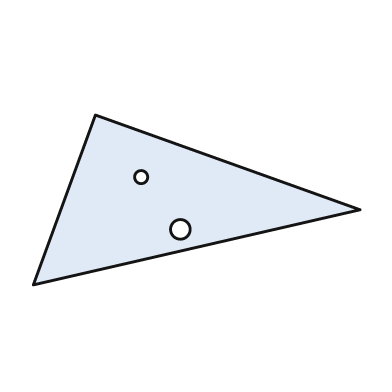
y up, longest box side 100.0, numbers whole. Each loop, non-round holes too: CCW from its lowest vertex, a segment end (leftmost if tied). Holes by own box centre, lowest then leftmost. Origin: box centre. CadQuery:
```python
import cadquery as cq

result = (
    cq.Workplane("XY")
    .moveTo(-50.0, -26.0)
    .lineTo(50.0, -3.0)
    .lineTo(-31.0, 26.0)
    .close()
    .moveTo(-5.0, -9.0)
    .circle(3.0)
    .moveTo(-17.0, 7.0)
    .circle(2.0)
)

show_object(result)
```